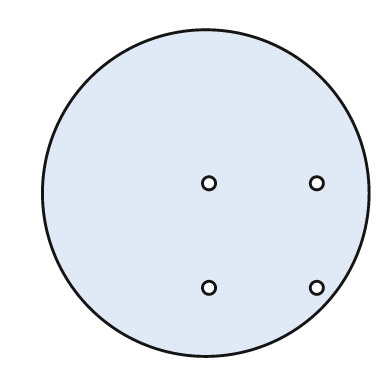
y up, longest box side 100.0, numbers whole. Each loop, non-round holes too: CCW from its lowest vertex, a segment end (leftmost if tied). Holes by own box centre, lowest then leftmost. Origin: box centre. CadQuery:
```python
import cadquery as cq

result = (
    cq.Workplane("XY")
    .moveTo(0.0, 0.0)
    .circle(50.0)
    .moveTo(1.0, -29.0)
    .circle(2.0)
    .moveTo(34.0, -29.0)
    .circle(2.0)
    .moveTo(1.0, 3.0)
    .circle(2.0)
    .moveTo(34.0, 3.0)
    .circle(2.0)
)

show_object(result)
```